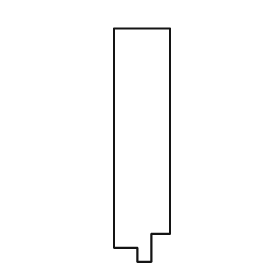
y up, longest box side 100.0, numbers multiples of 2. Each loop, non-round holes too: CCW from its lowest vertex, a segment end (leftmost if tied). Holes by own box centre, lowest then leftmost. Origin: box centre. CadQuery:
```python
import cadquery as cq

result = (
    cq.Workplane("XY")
    .moveTo(-2.0, -50.0)
    .lineTo(4.0, -50.0)
    .lineTo(4.0, -38.0)
    .lineTo(12.0, -38.0)
    .lineTo(12.0, 50.0)
    .lineTo(-12.0, 50.0)
    .lineTo(-12.0, -44.0)
    .lineTo(-2.0, -44.0)
    .close()
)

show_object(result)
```